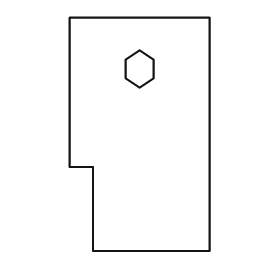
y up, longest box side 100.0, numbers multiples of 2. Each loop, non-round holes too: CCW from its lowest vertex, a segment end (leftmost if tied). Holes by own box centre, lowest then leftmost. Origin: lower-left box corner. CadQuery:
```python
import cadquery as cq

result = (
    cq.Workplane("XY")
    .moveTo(10.0, 0.0)
    .lineTo(60.0, 0.0)
    .lineTo(60.0, 100.0)
    .lineTo(0.0, 100.0)
    .lineTo(0.0, 36.0)
    .lineTo(10.0, 36.0)
    .close()
    .moveTo(30.0, 70.0)
    .lineTo(36.0, 74.0)
    .lineTo(36.0, 82.0)
    .lineTo(30.0, 86.0)
    .lineTo(24.0, 82.0)
    .lineTo(24.0, 74.0)
    .close()
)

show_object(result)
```